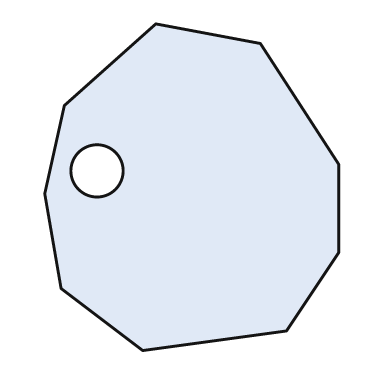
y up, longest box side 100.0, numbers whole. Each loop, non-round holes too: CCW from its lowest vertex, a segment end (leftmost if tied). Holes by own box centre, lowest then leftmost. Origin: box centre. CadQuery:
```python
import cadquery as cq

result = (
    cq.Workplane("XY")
    .moveTo(-15.0, -50.0)
    .lineTo(29.0, -44.0)
    .lineTo(45.0, -20.0)
    .lineTo(45.0, 7.0)
    .lineTo(21.0, 44.0)
    .lineTo(-11.0, 50.0)
    .lineTo(-39.0, 25.0)
    .lineTo(-45.0, -2.0)
    .lineTo(-40.0, -31.0)
    .close()
    .moveTo(-29.0, 5.0)
    .circle(8.0)
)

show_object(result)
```